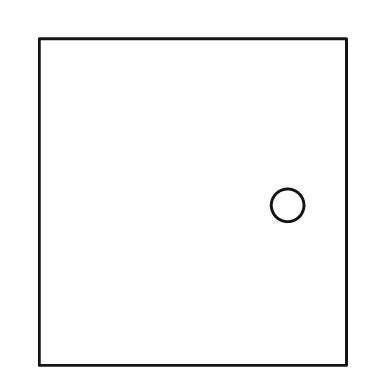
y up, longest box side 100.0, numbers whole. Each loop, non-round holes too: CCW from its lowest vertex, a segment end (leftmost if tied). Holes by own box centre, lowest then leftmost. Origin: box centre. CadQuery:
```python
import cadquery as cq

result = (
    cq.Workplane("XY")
    .moveTo(-47.0, -50.0)
    .lineTo(47.0, -50.0)
    .lineTo(47.0, 50.0)
    .lineTo(-47.0, 50.0)
    .close()
    .moveTo(29.0, -1.0)
    .circle(5.0)
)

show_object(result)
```